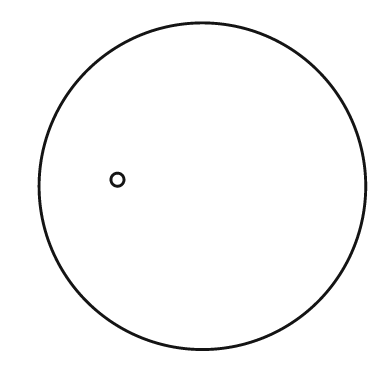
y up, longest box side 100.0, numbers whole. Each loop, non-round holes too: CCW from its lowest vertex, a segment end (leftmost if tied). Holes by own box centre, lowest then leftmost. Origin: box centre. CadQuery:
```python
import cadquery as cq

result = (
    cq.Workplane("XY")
    .moveTo(0.0, 0.0)
    .circle(50.0)
    .moveTo(-26.0, 2.0)
    .circle(2.0)
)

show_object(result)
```